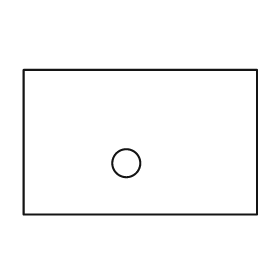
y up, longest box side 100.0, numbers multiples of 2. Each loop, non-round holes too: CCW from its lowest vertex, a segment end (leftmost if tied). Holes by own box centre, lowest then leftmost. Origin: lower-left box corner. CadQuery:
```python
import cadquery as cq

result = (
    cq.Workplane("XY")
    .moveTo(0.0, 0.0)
    .lineTo(100.0, 0.0)
    .lineTo(100.0, 62.0)
    .lineTo(0.0, 62.0)
    .close()
    .moveTo(44.0, 22.0)
    .circle(6.0)
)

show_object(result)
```